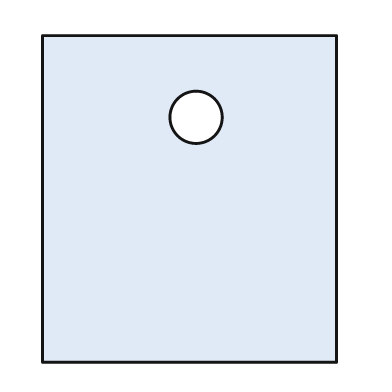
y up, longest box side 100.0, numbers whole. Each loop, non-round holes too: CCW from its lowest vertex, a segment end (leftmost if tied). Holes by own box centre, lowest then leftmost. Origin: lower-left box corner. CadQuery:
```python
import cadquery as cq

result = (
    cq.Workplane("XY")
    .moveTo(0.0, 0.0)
    .lineTo(90.0, 0.0)
    .lineTo(90.0, 100.0)
    .lineTo(0.0, 100.0)
    .close()
    .moveTo(47.0, 75.0)
    .circle(8.0)
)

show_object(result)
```